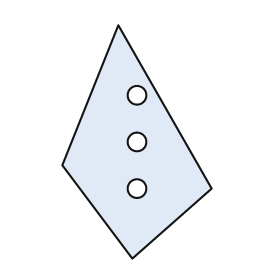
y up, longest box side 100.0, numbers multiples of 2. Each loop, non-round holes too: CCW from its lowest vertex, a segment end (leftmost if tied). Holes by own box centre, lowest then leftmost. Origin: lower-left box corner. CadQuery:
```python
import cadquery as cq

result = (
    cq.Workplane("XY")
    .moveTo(30.0, 0.0)
    .lineTo(64.0, 30.0)
    .lineTo(24.0, 100.0)
    .lineTo(0.0, 40.0)
    .close()
    .moveTo(32.0, 30.0)
    .circle(4.0)
    .moveTo(32.0, 50.0)
    .circle(4.0)
    .moveTo(32.0, 70.0)
    .circle(4.0)
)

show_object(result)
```